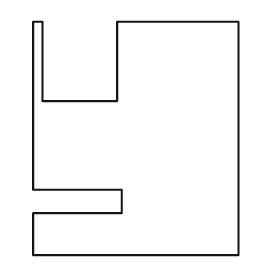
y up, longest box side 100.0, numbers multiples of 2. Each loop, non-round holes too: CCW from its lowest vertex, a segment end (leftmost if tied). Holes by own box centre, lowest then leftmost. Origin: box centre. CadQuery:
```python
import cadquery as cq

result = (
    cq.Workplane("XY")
    .moveTo(-44.0, -50.0)
    .lineTo(44.0, -50.0)
    .lineTo(44.0, 50.0)
    .lineTo(-8.0, 50.0)
    .lineTo(-8.0, 16.0)
    .lineTo(-40.0, 16.0)
    .lineTo(-40.0, 50.0)
    .lineTo(-44.0, 50.0)
    .lineTo(-44.0, -22.0)
    .lineTo(-6.0, -22.0)
    .lineTo(-6.0, -32.0)
    .lineTo(-44.0, -32.0)
    .close()
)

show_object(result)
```